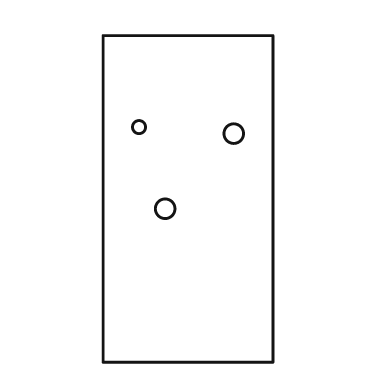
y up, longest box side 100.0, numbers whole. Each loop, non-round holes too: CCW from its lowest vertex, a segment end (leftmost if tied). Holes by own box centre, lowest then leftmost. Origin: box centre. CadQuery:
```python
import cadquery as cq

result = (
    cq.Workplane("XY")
    .moveTo(-26.0, -50.0)
    .lineTo(26.0, -50.0)
    .lineTo(26.0, 50.0)
    .lineTo(-26.0, 50.0)
    .close()
    .moveTo(-7.0, -3.0)
    .circle(3.0)
    .moveTo(14.0, 20.0)
    .circle(3.0)
    .moveTo(-15.0, 22.0)
    .circle(2.0)
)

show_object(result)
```